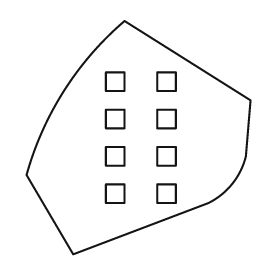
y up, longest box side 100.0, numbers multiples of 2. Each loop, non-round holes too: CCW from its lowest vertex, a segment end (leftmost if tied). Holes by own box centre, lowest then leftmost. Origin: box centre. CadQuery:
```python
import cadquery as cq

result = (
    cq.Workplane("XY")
    .moveTo(-28.0, -50.0)
    .lineTo(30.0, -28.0)
    .threePointArc((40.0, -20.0), (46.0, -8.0))
    .lineTo(48.0, 16.0)
    .lineTo(-6.0, 50.0)
    .threePointArc((-32.0, 20.0), (-48.0, -16.0))
    .close()
    .moveTo(-14.0, -28.0)
    .lineTo(-6.0, -28.0)
    .lineTo(-6.0, -20.0)
    .lineTo(-14.0, -20.0)
    .close()
    .moveTo(8.0, -28.0)
    .lineTo(16.0, -28.0)
    .lineTo(16.0, -20.0)
    .lineTo(8.0, -20.0)
    .close()
    .moveTo(-14.0, -12.0)
    .lineTo(-6.0, -12.0)
    .lineTo(-6.0, -4.0)
    .lineTo(-14.0, -4.0)
    .close()
    .moveTo(8.0, -12.0)
    .lineTo(16.0, -12.0)
    .lineTo(16.0, -4.0)
    .lineTo(8.0, -4.0)
    .close()
    .moveTo(-14.0, 4.0)
    .lineTo(-6.0, 4.0)
    .lineTo(-6.0, 12.0)
    .lineTo(-14.0, 12.0)
    .close()
    .moveTo(8.0, 4.0)
    .lineTo(16.0, 4.0)
    .lineTo(16.0, 12.0)
    .lineTo(8.0, 12.0)
    .close()
    .moveTo(-14.0, 20.0)
    .lineTo(-6.0, 20.0)
    .lineTo(-6.0, 28.0)
    .lineTo(-14.0, 28.0)
    .close()
    .moveTo(8.0, 20.0)
    .lineTo(16.0, 20.0)
    .lineTo(16.0, 28.0)
    .lineTo(8.0, 28.0)
    .close()
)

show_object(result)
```